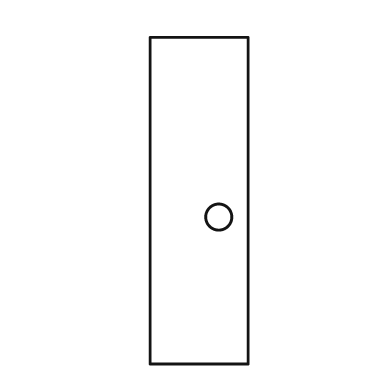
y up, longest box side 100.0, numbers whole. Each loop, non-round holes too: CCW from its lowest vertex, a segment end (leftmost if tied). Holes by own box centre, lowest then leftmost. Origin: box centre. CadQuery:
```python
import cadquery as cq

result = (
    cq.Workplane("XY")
    .moveTo(-15.0, -50.0)
    .lineTo(15.0, -50.0)
    .lineTo(15.0, 50.0)
    .lineTo(-15.0, 50.0)
    .close()
    .moveTo(6.0, -5.0)
    .circle(4.0)
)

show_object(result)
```